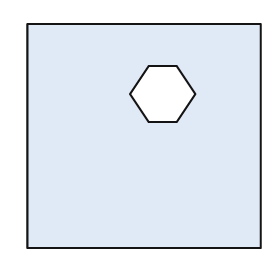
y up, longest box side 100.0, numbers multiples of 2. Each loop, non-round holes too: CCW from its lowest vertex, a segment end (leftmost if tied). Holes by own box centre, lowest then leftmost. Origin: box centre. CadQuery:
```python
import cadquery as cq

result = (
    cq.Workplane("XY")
    .moveTo(-50.0, -48.0)
    .lineTo(50.0, -48.0)
    .lineTo(50.0, 48.0)
    .lineTo(-50.0, 48.0)
    .close()
    .moveTo(2.0, 6.0)
    .lineTo(14.0, 6.0)
    .lineTo(22.0, 18.0)
    .lineTo(14.0, 30.0)
    .lineTo(2.0, 30.0)
    .lineTo(-6.0, 18.0)
    .close()
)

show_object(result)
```